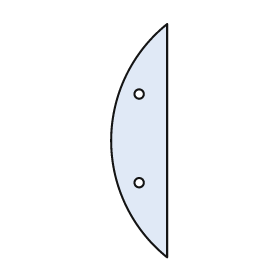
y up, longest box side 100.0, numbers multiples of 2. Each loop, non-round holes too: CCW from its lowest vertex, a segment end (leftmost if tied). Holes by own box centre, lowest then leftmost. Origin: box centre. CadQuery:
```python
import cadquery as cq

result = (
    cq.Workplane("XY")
    .moveTo(12.0, -50.0)
    .lineTo(12.0, 50.0)
    .threePointArc((-12.0, 0.0), (12.0, -50.0))
    .close()
    .moveTo(0.0, -18.0)
    .circle(2.0)
    .moveTo(0.0, 20.0)
    .circle(2.0)
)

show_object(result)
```